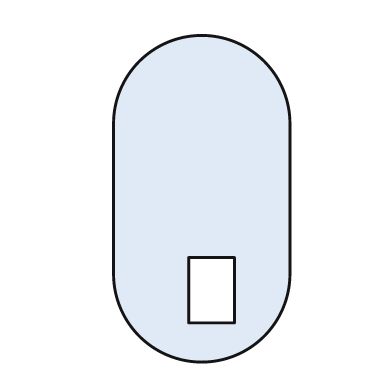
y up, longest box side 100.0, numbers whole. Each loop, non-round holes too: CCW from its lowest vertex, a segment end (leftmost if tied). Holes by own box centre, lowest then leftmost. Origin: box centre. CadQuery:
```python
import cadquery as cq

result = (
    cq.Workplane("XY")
    .moveTo(-27.0, -23.0)
    .threePointArc((0.0, -50.0), (27.0, -23.0))
    .lineTo(27.0, 23.0)
    .threePointArc((0.0, 50.0), (-27.0, 23.0))
    .close()
    .moveTo(-4.0, -38.0)
    .lineTo(10.0, -38.0)
    .lineTo(10.0, -18.0)
    .lineTo(-4.0, -18.0)
    .close()
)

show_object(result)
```